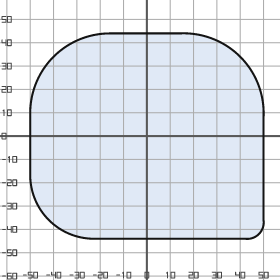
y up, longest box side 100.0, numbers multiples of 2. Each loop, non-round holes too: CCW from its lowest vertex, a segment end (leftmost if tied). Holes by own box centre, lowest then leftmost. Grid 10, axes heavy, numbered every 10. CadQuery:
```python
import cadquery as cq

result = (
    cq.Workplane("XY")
    .moveTo(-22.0, -44.0)
    .lineTo(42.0, -44.0)
    .threePointArc((48.0, -42.0), (50.0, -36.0))
    .lineTo(50.0, 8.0)
    .threePointArc((40.0, 34.0), (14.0, 44.0))
    .lineTo(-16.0, 44.0)
    .threePointArc((-40.0, 34.0), (-50.0, 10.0))
    .lineTo(-50.0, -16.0)
    .threePointArc((-42.0, -36.0), (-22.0, -44.0))
    .close()
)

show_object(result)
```